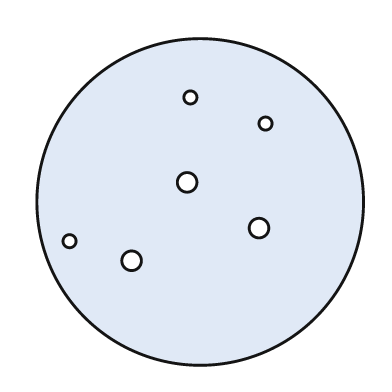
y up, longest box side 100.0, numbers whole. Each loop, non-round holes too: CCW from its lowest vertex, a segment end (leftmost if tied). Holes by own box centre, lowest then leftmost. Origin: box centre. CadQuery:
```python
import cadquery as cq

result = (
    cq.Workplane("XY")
    .moveTo(0.0, 0.0)
    .circle(50.0)
    .moveTo(-21.0, -18.0)
    .circle(3.0)
    .moveTo(-40.0, -12.0)
    .circle(2.0)
    .moveTo(18.0, -8.0)
    .circle(3.0)
    .moveTo(-4.0, 6.0)
    .circle(3.0)
    .moveTo(20.0, 24.0)
    .circle(2.0)
    .moveTo(-3.0, 32.0)
    .circle(2.0)
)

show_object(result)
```